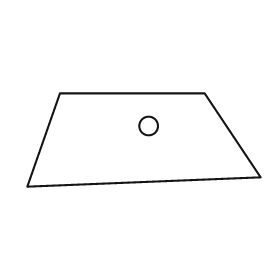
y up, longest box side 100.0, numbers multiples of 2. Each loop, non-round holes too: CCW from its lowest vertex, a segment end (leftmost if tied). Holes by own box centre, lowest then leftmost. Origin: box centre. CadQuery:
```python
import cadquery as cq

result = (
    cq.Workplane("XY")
    .moveTo(-50.0, -20.0)
    .lineTo(50.0, -16.0)
    .lineTo(26.0, 20.0)
    .lineTo(-36.0, 20.0)
    .close()
    .moveTo(2.0, 6.0)
    .circle(4.0)
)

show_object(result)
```